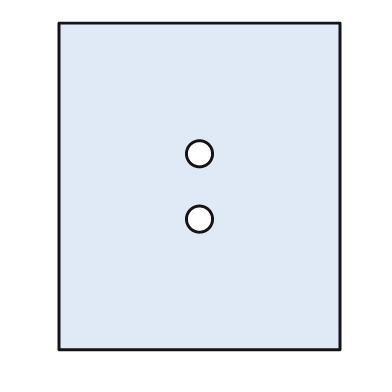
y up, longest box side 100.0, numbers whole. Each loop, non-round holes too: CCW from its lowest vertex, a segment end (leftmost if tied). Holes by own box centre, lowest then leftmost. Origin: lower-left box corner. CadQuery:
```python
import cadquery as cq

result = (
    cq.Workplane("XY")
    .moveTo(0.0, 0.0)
    .lineTo(86.0, 0.0)
    .lineTo(86.0, 100.0)
    .lineTo(0.0, 100.0)
    .close()
    .moveTo(43.0, 40.0)
    .circle(4.0)
    .moveTo(43.0, 60.0)
    .circle(4.0)
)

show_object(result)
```